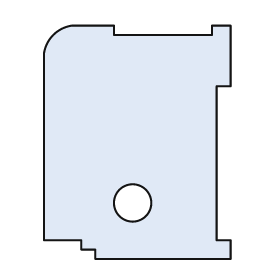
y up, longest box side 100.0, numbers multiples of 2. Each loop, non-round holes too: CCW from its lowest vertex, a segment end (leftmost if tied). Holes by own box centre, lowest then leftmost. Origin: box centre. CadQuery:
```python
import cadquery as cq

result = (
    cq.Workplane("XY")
    .moveTo(-18.0, -50.0)
    .lineTo(40.0, -50.0)
    .lineTo(40.0, -42.0)
    .lineTo(34.0, -42.0)
    .lineTo(34.0, 24.0)
    .lineTo(40.0, 24.0)
    .lineTo(40.0, 50.0)
    .lineTo(32.0, 50.0)
    .lineTo(32.0, 46.0)
    .lineTo(-10.0, 46.0)
    .lineTo(-10.0, 50.0)
    .lineTo(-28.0, 50.0)
    .threePointArc((-36.0, 46.0), (-40.0, 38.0))
    .lineTo(-40.0, -42.0)
    .lineTo(-24.0, -42.0)
    .lineTo(-24.0, -46.0)
    .lineTo(-18.0, -46.0)
    .close()
    .moveTo(-2.0, -26.0)
    .circle(8.0)
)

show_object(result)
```